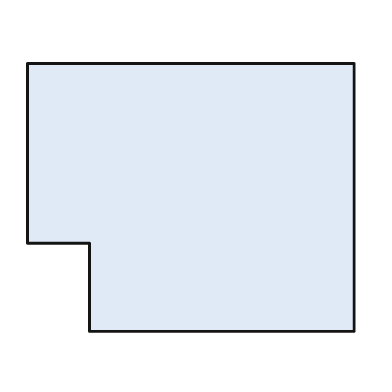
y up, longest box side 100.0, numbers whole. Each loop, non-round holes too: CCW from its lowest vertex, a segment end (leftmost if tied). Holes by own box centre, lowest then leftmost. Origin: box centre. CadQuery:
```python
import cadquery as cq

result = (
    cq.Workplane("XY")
    .moveTo(-31.0, -41.0)
    .lineTo(50.0, -41.0)
    .lineTo(50.0, 41.0)
    .lineTo(-50.0, 41.0)
    .lineTo(-50.0, -14.0)
    .lineTo(-31.0, -14.0)
    .close()
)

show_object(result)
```